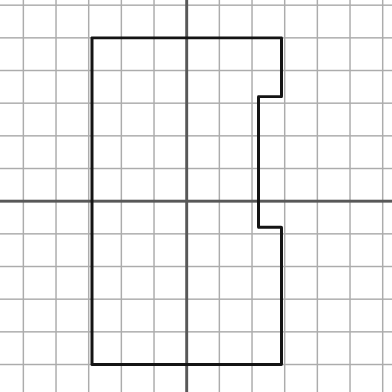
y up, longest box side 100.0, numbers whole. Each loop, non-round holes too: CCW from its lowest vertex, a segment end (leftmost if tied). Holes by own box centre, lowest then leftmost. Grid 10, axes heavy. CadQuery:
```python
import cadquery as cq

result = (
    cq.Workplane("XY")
    .moveTo(-29.0, -50.0)
    .lineTo(29.0, -50.0)
    .lineTo(29.0, -8.0)
    .lineTo(22.0, -8.0)
    .lineTo(22.0, 32.0)
    .lineTo(29.0, 32.0)
    .lineTo(29.0, 50.0)
    .lineTo(-29.0, 50.0)
    .close()
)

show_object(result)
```